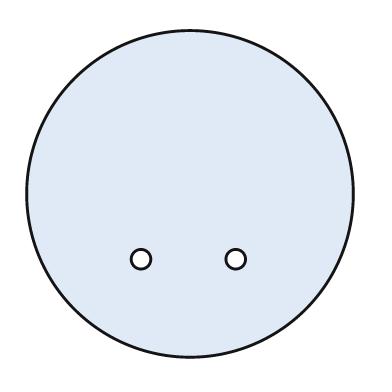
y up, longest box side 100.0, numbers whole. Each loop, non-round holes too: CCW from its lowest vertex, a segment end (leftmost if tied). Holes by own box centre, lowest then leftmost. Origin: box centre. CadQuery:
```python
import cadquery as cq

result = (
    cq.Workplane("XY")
    .moveTo(0.0, 0.0)
    .circle(50.0)
    .moveTo(-15.0, -20.0)
    .circle(3.0)
    .moveTo(14.0, -20.0)
    .circle(3.0)
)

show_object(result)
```